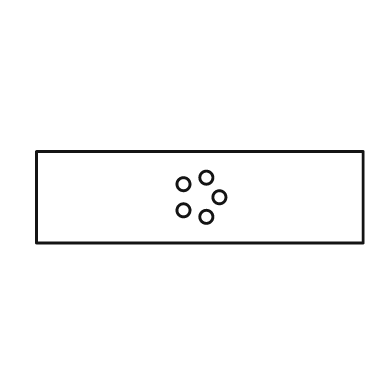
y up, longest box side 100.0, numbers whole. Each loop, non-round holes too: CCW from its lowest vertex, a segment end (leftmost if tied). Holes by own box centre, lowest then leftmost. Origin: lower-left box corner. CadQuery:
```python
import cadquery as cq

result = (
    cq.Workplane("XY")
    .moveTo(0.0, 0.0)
    .lineTo(100.0, 0.0)
    .lineTo(100.0, 28.0)
    .lineTo(0.0, 28.0)
    .close()
    .moveTo(52.0, 8.0)
    .circle(2.0)
    .moveTo(45.0, 10.0)
    .circle(2.0)
    .moveTo(56.0, 14.0)
    .circle(2.0)
    .moveTo(45.0, 18.0)
    .circle(2.0)
    .moveTo(52.0, 20.0)
    .circle(2.0)
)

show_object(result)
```